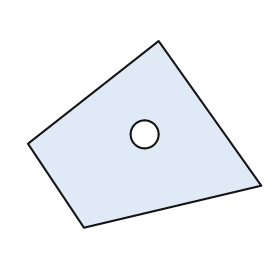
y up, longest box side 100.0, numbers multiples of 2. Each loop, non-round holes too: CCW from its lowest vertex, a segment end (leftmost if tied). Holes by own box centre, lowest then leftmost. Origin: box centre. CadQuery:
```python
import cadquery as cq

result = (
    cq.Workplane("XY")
    .moveTo(-26.0, -40.0)
    .lineTo(50.0, -22.0)
    .lineTo(6.0, 40.0)
    .lineTo(-50.0, -4.0)
    .close()
    .moveTo(0.0, 0.0)
    .circle(6.0)
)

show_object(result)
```